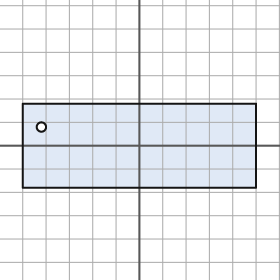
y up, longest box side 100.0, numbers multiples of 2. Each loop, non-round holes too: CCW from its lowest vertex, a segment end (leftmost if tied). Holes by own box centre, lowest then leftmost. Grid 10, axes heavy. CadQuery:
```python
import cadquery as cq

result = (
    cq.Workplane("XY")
    .moveTo(-50.0, -18.0)
    .lineTo(50.0, -18.0)
    .lineTo(50.0, 18.0)
    .lineTo(-50.0, 18.0)
    .close()
    .moveTo(-42.0, 8.0)
    .circle(2.0)
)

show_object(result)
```